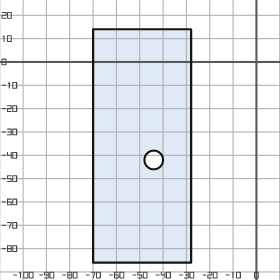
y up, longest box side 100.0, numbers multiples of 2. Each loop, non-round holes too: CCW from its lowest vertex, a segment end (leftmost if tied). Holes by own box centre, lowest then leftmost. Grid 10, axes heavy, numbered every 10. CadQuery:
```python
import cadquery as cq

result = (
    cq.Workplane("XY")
    .moveTo(-70.0, -86.0)
    .lineTo(-28.0, -86.0)
    .lineTo(-28.0, 14.0)
    .lineTo(-70.0, 14.0)
    .close()
    .moveTo(-44.0, -42.0)
    .circle(4.0)
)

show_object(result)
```